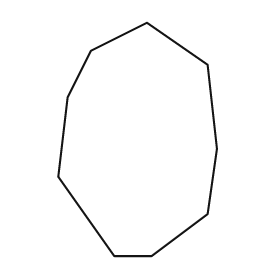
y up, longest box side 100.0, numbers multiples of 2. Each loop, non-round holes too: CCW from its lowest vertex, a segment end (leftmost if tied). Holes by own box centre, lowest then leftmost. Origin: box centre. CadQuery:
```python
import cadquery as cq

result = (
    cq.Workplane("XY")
    .moveTo(-10.0, -50.0)
    .lineTo(6.0, -50.0)
    .lineTo(30.0, -32.0)
    .lineTo(34.0, -4.0)
    .lineTo(30.0, 32.0)
    .lineTo(4.0, 50.0)
    .lineTo(-20.0, 38.0)
    .lineTo(-30.0, 18.0)
    .lineTo(-34.0, -16.0)
    .close()
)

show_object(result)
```